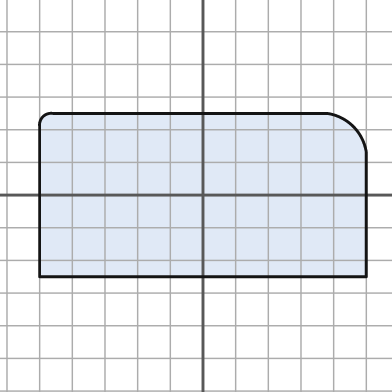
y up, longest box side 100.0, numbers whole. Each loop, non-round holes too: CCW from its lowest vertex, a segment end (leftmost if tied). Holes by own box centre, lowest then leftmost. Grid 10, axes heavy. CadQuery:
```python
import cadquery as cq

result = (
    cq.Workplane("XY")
    .moveTo(-50.0, -25.0)
    .lineTo(50.0, -25.0)
    .lineTo(50.0, 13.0)
    .threePointArc((46.0, 21.0), (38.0, 25.0))
    .lineTo(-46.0, 25.0)
    .threePointArc((-49.0, 24.0), (-50.0, 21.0))
    .close()
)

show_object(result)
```